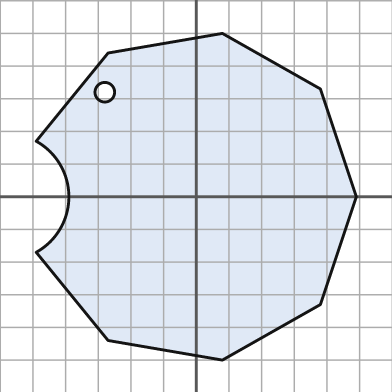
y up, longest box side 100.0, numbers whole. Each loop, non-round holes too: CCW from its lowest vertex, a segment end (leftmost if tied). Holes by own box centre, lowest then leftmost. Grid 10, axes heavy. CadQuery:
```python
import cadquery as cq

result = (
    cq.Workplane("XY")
    .moveTo(8.0, -50.0)
    .lineTo(38.0, -33.0)
    .lineTo(49.0, 0.0)
    .lineTo(38.0, 33.0)
    .lineTo(8.0, 50.0)
    .lineTo(-27.0, 44.0)
    .lineTo(-49.0, 17.0)
    .threePointArc((-39.0, 0.0), (-49.0, -17.0))
    .lineTo(-27.0, -44.0)
    .close()
    .moveTo(-28.0, 32.0)
    .circle(3.0)
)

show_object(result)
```